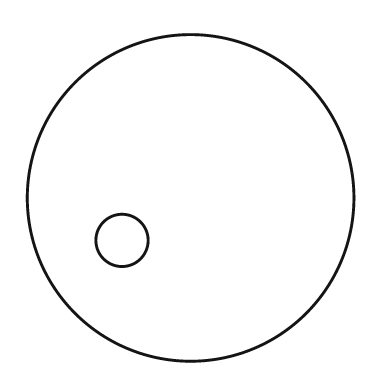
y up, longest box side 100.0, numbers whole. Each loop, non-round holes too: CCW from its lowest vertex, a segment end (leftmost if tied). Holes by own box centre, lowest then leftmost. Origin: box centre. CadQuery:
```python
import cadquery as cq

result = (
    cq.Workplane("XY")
    .moveTo(0.0, 0.0)
    .circle(50.0)
    .moveTo(-21.0, -13.0)
    .circle(8.0)
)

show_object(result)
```